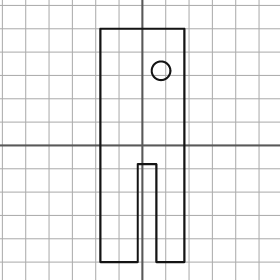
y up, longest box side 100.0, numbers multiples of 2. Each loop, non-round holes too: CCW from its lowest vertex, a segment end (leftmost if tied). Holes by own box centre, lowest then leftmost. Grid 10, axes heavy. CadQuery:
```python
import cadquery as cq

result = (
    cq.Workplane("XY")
    .moveTo(-18.0, -50.0)
    .lineTo(-2.0, -50.0)
    .lineTo(-2.0, -8.0)
    .lineTo(6.0, -8.0)
    .lineTo(6.0, -50.0)
    .lineTo(18.0, -50.0)
    .lineTo(18.0, 50.0)
    .lineTo(-18.0, 50.0)
    .close()
    .moveTo(8.0, 32.0)
    .circle(4.0)
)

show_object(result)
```